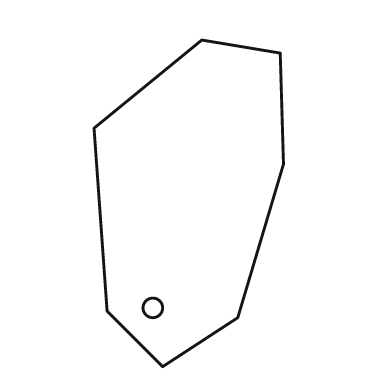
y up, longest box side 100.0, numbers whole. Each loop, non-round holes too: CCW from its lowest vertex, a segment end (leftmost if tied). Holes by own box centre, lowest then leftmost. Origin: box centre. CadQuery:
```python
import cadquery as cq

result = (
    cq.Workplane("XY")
    .moveTo(-8.0, -50.0)
    .lineTo(15.0, -35.0)
    .lineTo(29.0, 12.0)
    .lineTo(28.0, 46.0)
    .lineTo(4.0, 50.0)
    .lineTo(-29.0, 23.0)
    .lineTo(-25.0, -33.0)
    .close()
    .moveTo(-11.0, -32.0)
    .circle(3.0)
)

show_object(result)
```